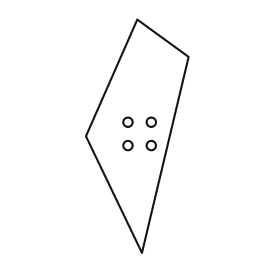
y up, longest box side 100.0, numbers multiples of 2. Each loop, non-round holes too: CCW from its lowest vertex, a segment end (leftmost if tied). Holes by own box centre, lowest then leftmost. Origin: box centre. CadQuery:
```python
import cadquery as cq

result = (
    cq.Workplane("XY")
    .moveTo(2.0, -50.0)
    .lineTo(22.0, 34.0)
    .lineTo(0.0, 50.0)
    .lineTo(-22.0, 0.0)
    .close()
    .moveTo(-4.0, -4.0)
    .circle(2.0)
    .moveTo(6.0, -4.0)
    .circle(2.0)
    .moveTo(-4.0, 6.0)
    .circle(2.0)
    .moveTo(6.0, 6.0)
    .circle(2.0)
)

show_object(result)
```